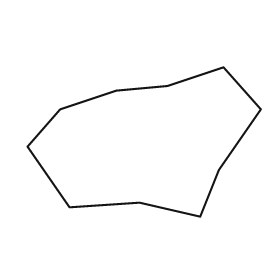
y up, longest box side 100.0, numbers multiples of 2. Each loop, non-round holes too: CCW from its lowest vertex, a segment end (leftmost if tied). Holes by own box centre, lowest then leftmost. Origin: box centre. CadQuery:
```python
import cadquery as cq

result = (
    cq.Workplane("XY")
    .moveTo(24.0, -32.0)
    .lineTo(32.0, -12.0)
    .lineTo(50.0, 14.0)
    .lineTo(34.0, 32.0)
    .lineTo(10.0, 24.0)
    .lineTo(-12.0, 22.0)
    .lineTo(-36.0, 14.0)
    .lineTo(-50.0, -2.0)
    .lineTo(-32.0, -28.0)
    .lineTo(-2.0, -26.0)
    .close()
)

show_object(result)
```